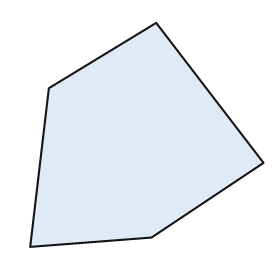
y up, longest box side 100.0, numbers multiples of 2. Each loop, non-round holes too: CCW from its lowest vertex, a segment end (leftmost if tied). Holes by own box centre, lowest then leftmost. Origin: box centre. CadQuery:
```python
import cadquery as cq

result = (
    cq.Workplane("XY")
    .moveTo(-50.0, -48.0)
    .lineTo(2.0, -44.0)
    .lineTo(50.0, -12.0)
    .lineTo(4.0, 48.0)
    .lineTo(-42.0, 20.0)
    .close()
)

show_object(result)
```